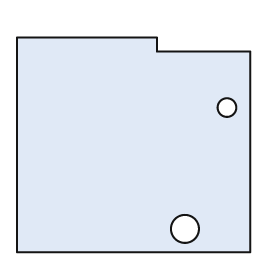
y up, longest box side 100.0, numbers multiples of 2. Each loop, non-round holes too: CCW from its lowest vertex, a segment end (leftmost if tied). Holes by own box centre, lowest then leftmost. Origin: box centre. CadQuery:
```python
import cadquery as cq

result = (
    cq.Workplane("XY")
    .moveTo(-50.0, -46.0)
    .lineTo(50.0, -46.0)
    .lineTo(50.0, 40.0)
    .lineTo(10.0, 40.0)
    .lineTo(10.0, 46.0)
    .lineTo(-50.0, 46.0)
    .close()
    .moveTo(22.0, -36.0)
    .circle(6.0)
    .moveTo(40.0, 16.0)
    .circle(4.0)
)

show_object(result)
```